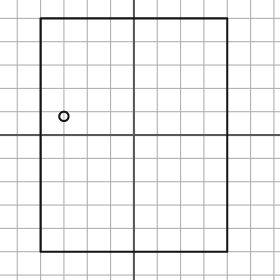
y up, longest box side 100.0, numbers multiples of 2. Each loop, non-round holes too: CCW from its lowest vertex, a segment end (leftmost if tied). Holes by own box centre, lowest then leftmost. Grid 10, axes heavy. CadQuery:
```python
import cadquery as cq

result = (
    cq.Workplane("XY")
    .moveTo(-40.0, -50.0)
    .lineTo(40.0, -50.0)
    .lineTo(40.0, 50.0)
    .lineTo(-40.0, 50.0)
    .close()
    .moveTo(-30.0, 8.0)
    .circle(2.0)
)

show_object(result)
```